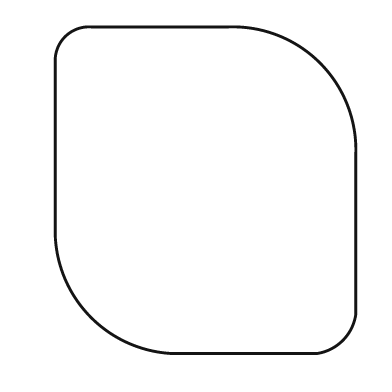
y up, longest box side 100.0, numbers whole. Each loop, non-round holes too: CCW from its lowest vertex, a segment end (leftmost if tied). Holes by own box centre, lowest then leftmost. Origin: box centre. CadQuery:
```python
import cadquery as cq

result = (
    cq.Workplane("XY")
    .moveTo(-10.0, -50.0)
    .lineTo(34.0, -50.0)
    .threePointArc((42.0, -46.0), (46.0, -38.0))
    .lineTo(46.0, 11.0)
    .threePointArc((35.0, 39.0), (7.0, 50.0))
    .lineTo(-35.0, 50.0)
    .threePointArc((-43.0, 47.0), (-46.0, 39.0))
    .lineTo(-46.0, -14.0)
    .threePointArc((-35.0, -39.0), (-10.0, -50.0))
    .close()
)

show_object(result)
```